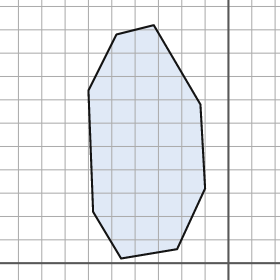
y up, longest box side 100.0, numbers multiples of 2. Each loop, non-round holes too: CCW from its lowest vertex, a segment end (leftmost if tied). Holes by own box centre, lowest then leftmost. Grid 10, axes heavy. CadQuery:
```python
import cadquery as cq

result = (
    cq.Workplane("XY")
    .moveTo(-46.0, 2.0)
    .lineTo(-22.0, 6.0)
    .lineTo(-10.0, 32.0)
    .lineTo(-12.0, 68.0)
    .lineTo(-32.0, 102.0)
    .lineTo(-48.0, 98.0)
    .lineTo(-60.0, 74.0)
    .lineTo(-58.0, 22.0)
    .close()
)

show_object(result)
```